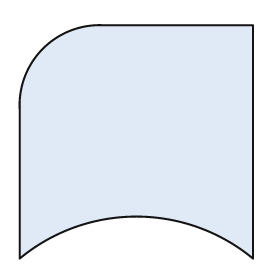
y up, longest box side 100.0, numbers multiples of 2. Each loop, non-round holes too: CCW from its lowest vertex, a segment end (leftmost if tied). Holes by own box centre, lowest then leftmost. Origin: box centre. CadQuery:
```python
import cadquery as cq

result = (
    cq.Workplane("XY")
    .moveTo(-50.0, -50.0)
    .threePointArc((0.0, -32.0), (50.0, -50.0))
    .lineTo(50.0, 50.0)
    .lineTo(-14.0, 50.0)
    .threePointArc((-40.0, 40.0), (-50.0, 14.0))
    .close()
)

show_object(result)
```